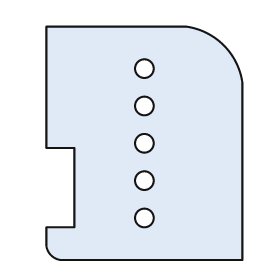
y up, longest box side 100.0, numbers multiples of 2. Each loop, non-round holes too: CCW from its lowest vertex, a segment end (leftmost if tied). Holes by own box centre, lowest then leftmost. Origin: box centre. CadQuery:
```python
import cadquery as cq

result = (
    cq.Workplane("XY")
    .moveTo(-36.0, -50.0)
    .lineTo(42.0, -50.0)
    .lineTo(42.0, 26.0)
    .threePointArc((34.0, 42.0), (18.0, 50.0))
    .lineTo(-42.0, 50.0)
    .lineTo(-42.0, -2.0)
    .lineTo(-30.0, -2.0)
    .lineTo(-30.0, -36.0)
    .lineTo(-42.0, -36.0)
    .lineTo(-42.0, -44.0)
    .threePointArc((-40.0, -48.0), (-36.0, -50.0))
    .close()
    .moveTo(0.0, -32.0)
    .circle(4.0)
    .moveTo(0.0, -16.0)
    .circle(4.0)
    .moveTo(0.0, 0.0)
    .circle(4.0)
    .moveTo(0.0, 16.0)
    .circle(4.0)
    .moveTo(0.0, 32.0)
    .circle(4.0)
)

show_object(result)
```